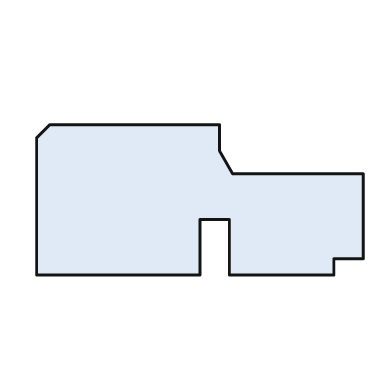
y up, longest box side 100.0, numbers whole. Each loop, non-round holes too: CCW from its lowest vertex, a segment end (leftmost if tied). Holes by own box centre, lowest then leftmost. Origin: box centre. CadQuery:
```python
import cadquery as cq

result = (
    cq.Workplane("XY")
    .moveTo(-50.0, -23.0)
    .lineTo(0.0, -23.0)
    .lineTo(0.0, -6.0)
    .lineTo(9.0, -6.0)
    .lineTo(9.0, -23.0)
    .lineTo(41.0, -23.0)
    .lineTo(41.0, -18.0)
    .lineTo(50.0, -18.0)
    .lineTo(50.0, 8.0)
    .lineTo(10.0, 8.0)
    .lineTo(6.0, 15.0)
    .lineTo(6.0, 23.0)
    .lineTo(-46.0, 23.0)
    .lineTo(-50.0, 19.0)
    .close()
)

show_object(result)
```